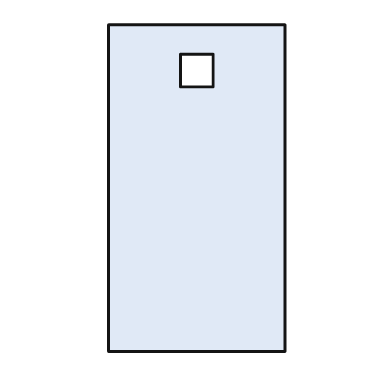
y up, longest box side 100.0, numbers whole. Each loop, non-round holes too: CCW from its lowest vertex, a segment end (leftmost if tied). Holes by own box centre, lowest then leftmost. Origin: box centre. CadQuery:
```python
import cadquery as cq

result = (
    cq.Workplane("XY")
    .moveTo(-27.0, -50.0)
    .lineTo(27.0, -50.0)
    .lineTo(27.0, 50.0)
    .lineTo(-27.0, 50.0)
    .close()
    .moveTo(-5.0, 31.0)
    .lineTo(5.0, 31.0)
    .lineTo(5.0, 41.0)
    .lineTo(-5.0, 41.0)
    .close()
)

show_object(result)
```